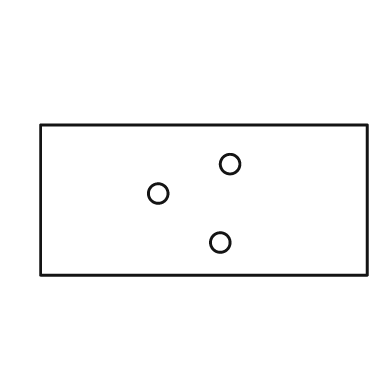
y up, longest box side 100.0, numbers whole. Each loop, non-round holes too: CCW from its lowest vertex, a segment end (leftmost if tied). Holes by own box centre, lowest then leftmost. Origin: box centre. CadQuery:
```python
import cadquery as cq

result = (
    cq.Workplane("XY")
    .moveTo(-50.0, -23.0)
    .lineTo(50.0, -23.0)
    .lineTo(50.0, 23.0)
    .lineTo(-50.0, 23.0)
    .close()
    .moveTo(5.0, -13.0)
    .circle(3.0)
    .moveTo(-14.0, 2.0)
    .circle(3.0)
    .moveTo(8.0, 11.0)
    .circle(3.0)
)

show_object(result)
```